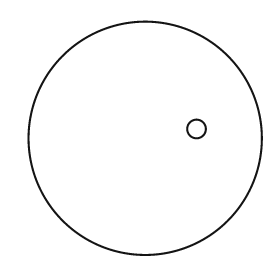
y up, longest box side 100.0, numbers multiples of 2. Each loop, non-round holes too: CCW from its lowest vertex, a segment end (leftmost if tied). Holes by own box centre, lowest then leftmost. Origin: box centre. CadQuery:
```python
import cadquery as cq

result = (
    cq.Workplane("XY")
    .moveTo(0.0, 0.0)
    .circle(50.0)
    .moveTo(22.0, 4.0)
    .circle(4.0)
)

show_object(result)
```